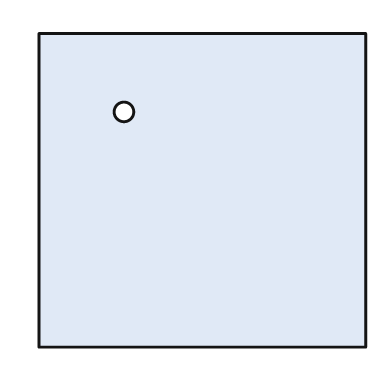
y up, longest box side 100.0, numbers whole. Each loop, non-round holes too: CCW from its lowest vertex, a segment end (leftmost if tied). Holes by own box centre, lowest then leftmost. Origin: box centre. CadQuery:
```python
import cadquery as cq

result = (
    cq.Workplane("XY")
    .moveTo(-50.0, -48.0)
    .lineTo(50.0, -48.0)
    .lineTo(50.0, 48.0)
    .lineTo(-50.0, 48.0)
    .close()
    .moveTo(-24.0, 24.0)
    .circle(3.0)
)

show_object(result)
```